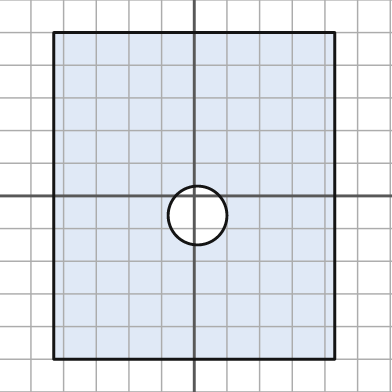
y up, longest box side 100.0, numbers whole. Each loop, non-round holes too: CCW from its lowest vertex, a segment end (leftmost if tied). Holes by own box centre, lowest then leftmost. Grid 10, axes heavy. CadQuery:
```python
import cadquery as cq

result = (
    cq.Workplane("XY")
    .moveTo(-43.0, -50.0)
    .lineTo(43.0, -50.0)
    .lineTo(43.0, 50.0)
    .lineTo(-43.0, 50.0)
    .close()
    .moveTo(1.0, -6.0)
    .circle(9.0)
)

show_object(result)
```